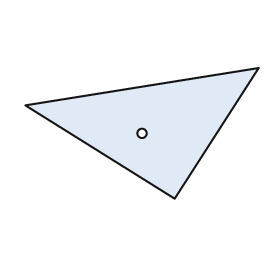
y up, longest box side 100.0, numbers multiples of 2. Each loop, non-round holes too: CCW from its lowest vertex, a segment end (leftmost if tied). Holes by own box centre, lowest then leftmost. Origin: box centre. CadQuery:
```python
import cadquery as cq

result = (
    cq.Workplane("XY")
    .moveTo(14.0, -28.0)
    .lineTo(50.0, 28.0)
    .lineTo(-50.0, 12.0)
    .close()
    .moveTo(0.0, 0.0)
    .circle(2.0)
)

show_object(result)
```